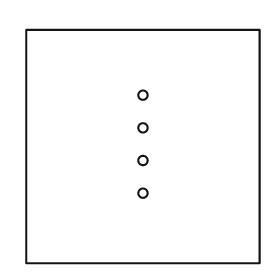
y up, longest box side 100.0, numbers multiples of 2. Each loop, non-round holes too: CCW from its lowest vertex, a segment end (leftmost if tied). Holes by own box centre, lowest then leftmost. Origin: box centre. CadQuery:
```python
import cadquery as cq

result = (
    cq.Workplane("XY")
    .moveTo(-50.0, -50.0)
    .lineTo(50.0, -50.0)
    .lineTo(50.0, 50.0)
    .lineTo(-50.0, 50.0)
    .close()
    .moveTo(0.0, -20.0)
    .circle(2.0)
    .moveTo(0.0, -6.0)
    .circle(2.0)
    .moveTo(0.0, 8.0)
    .circle(2.0)
    .moveTo(0.0, 22.0)
    .circle(2.0)
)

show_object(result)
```